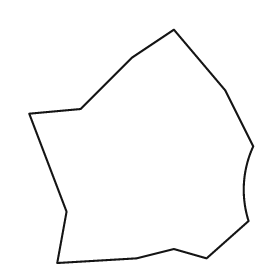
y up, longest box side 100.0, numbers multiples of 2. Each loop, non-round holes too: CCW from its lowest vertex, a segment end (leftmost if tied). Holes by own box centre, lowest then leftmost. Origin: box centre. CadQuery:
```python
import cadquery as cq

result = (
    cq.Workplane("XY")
    .moveTo(-36.0, -50.0)
    .lineTo(-2.0, -48.0)
    .lineTo(14.0, -44.0)
    .lineTo(28.0, -48.0)
    .lineTo(46.0, -32.0)
    .threePointArc((44.0, -16.0), (48.0, 0.0))
    .lineTo(36.0, 24.0)
    .lineTo(14.0, 50.0)
    .lineTo(-4.0, 38.0)
    .lineTo(-26.0, 16.0)
    .lineTo(-48.0, 14.0)
    .lineTo(-32.0, -28.0)
    .close()
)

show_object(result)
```